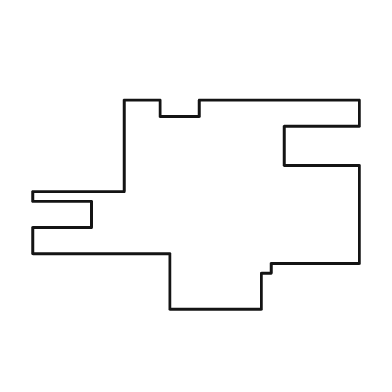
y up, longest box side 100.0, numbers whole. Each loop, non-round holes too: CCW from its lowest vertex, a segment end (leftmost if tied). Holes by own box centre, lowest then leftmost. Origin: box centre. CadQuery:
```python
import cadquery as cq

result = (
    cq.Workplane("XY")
    .moveTo(-8.0, -32.0)
    .lineTo(20.0, -32.0)
    .lineTo(20.0, -21.0)
    .lineTo(23.0, -21.0)
    .lineTo(23.0, -18.0)
    .lineTo(50.0, -18.0)
    .lineTo(50.0, 12.0)
    .lineTo(27.0, 12.0)
    .lineTo(27.0, 24.0)
    .lineTo(50.0, 24.0)
    .lineTo(50.0, 32.0)
    .lineTo(1.0, 32.0)
    .lineTo(1.0, 27.0)
    .lineTo(-11.0, 27.0)
    .lineTo(-11.0, 32.0)
    .lineTo(-22.0, 32.0)
    .lineTo(-22.0, 4.0)
    .lineTo(-50.0, 4.0)
    .lineTo(-50.0, 1.0)
    .lineTo(-32.0, 1.0)
    .lineTo(-32.0, -7.0)
    .lineTo(-50.0, -7.0)
    .lineTo(-50.0, -15.0)
    .lineTo(-8.0, -15.0)
    .close()
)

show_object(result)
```